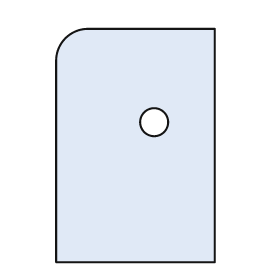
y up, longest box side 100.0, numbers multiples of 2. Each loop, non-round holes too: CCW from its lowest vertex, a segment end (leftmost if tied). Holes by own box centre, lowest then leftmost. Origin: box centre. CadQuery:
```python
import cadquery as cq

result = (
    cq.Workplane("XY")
    .moveTo(-34.0, -50.0)
    .lineTo(34.0, -50.0)
    .lineTo(34.0, 50.0)
    .lineTo(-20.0, 50.0)
    .threePointArc((-30.0, 46.0), (-34.0, 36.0))
    .close()
    .moveTo(8.0, 10.0)
    .circle(6.0)
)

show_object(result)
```